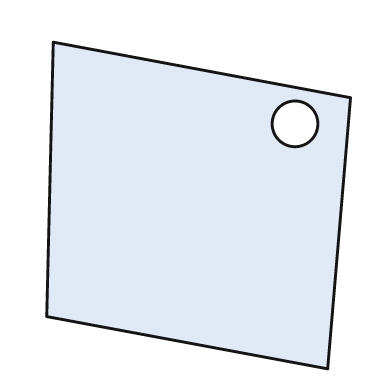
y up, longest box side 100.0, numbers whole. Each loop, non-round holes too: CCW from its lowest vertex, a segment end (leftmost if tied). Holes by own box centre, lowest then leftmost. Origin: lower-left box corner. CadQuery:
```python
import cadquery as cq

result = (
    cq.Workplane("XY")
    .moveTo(86.0, 0.0)
    .lineTo(93.0, 83.0)
    .lineTo(2.0, 100.0)
    .lineTo(0.0, 16.0)
    .close()
    .moveTo(76.0, 75.0)
    .circle(7.0)
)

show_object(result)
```